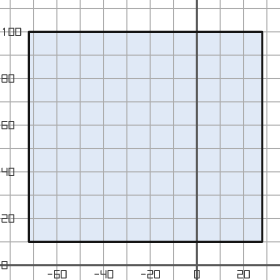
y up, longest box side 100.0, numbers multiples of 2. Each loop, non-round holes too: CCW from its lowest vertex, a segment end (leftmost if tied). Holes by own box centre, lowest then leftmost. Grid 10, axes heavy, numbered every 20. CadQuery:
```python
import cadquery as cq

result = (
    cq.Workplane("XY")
    .moveTo(-72.0, 10.0)
    .lineTo(28.0, 10.0)
    .lineTo(28.0, 100.0)
    .lineTo(-72.0, 100.0)
    .close()
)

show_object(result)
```